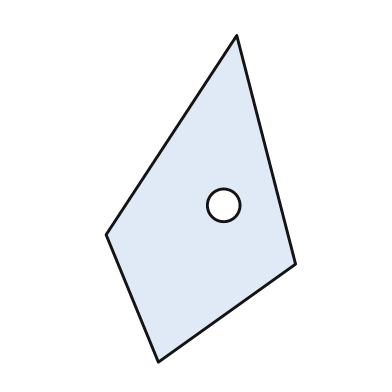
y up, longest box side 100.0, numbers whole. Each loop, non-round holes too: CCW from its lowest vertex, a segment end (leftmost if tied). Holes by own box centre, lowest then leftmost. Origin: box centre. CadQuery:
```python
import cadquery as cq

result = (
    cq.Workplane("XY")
    .moveTo(-13.0, -50.0)
    .lineTo(29.0, -20.0)
    .lineTo(11.0, 50.0)
    .lineTo(-29.0, -11.0)
    .close()
    .moveTo(7.0, -2.0)
    .circle(5.0)
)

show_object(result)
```